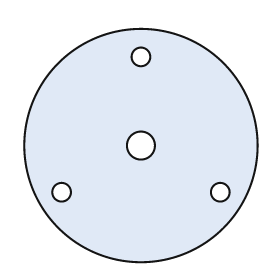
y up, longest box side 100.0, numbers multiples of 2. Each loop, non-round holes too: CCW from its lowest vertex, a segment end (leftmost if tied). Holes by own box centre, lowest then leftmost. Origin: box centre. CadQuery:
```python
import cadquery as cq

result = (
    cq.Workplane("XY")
    .moveTo(0.0, 0.0)
    .circle(50.0)
    .moveTo(-34.0, -20.0)
    .circle(4.0)
    .moveTo(34.0, -20.0)
    .circle(4.0)
    .moveTo(0.0, 0.0)
    .circle(6.0)
    .moveTo(0.0, 38.0)
    .circle(4.0)
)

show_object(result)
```